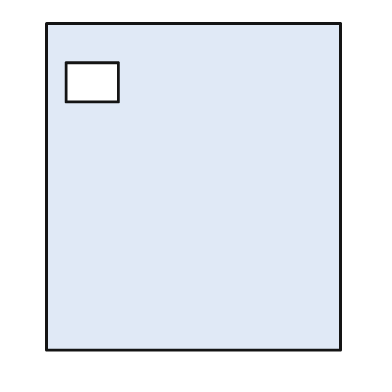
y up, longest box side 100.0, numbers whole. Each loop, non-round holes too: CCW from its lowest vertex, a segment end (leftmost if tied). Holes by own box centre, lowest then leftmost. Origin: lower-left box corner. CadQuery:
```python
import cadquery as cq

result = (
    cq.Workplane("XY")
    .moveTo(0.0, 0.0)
    .lineTo(90.0, 0.0)
    .lineTo(90.0, 100.0)
    .lineTo(0.0, 100.0)
    .close()
    .moveTo(6.0, 76.0)
    .lineTo(22.0, 76.0)
    .lineTo(22.0, 88.0)
    .lineTo(6.0, 88.0)
    .close()
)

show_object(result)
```